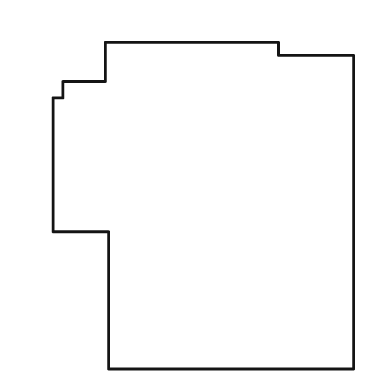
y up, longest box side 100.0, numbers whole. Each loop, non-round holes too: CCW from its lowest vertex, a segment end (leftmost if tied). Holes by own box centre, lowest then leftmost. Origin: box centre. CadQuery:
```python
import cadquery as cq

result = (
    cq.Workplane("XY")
    .moveTo(-29.0, -50.0)
    .lineTo(46.0, -50.0)
    .lineTo(46.0, 46.0)
    .lineTo(23.0, 46.0)
    .lineTo(23.0, 50.0)
    .lineTo(-30.0, 50.0)
    .lineTo(-30.0, 38.0)
    .lineTo(-43.0, 38.0)
    .lineTo(-43.0, 33.0)
    .lineTo(-46.0, 33.0)
    .lineTo(-46.0, -8.0)
    .lineTo(-29.0, -8.0)
    .close()
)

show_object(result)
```